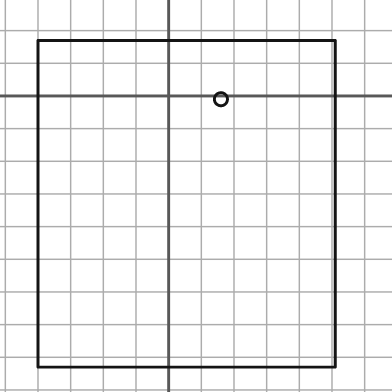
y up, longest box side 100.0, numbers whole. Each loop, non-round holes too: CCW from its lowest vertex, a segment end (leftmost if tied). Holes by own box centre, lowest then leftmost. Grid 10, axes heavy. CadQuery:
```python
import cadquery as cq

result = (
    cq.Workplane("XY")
    .moveTo(-40.0, -83.0)
    .lineTo(51.0, -83.0)
    .lineTo(51.0, 17.0)
    .lineTo(-40.0, 17.0)
    .close()
    .moveTo(16.0, -1.0)
    .circle(2.0)
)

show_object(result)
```